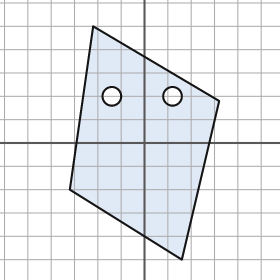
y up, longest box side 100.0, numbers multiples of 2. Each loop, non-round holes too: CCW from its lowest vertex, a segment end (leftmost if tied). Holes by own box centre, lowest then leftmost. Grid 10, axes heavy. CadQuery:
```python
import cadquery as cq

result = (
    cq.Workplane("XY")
    .moveTo(16.0, -50.0)
    .lineTo(32.0, 18.0)
    .lineTo(-22.0, 50.0)
    .lineTo(-32.0, -20.0)
    .close()
    .moveTo(-14.0, 20.0)
    .circle(4.0)
    .moveTo(12.0, 20.0)
    .circle(4.0)
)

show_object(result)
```